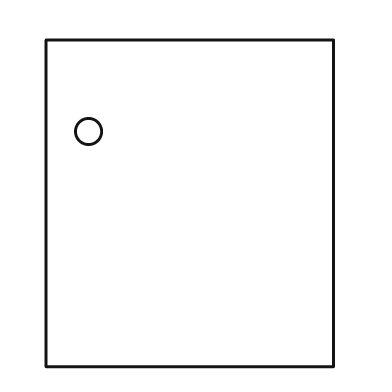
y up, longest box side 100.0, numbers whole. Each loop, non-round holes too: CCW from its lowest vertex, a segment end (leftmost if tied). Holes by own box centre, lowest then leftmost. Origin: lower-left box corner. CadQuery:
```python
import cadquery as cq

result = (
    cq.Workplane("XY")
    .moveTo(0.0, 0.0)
    .lineTo(88.0, 0.0)
    .lineTo(88.0, 100.0)
    .lineTo(0.0, 100.0)
    .close()
    .moveTo(13.0, 72.0)
    .circle(4.0)
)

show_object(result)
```